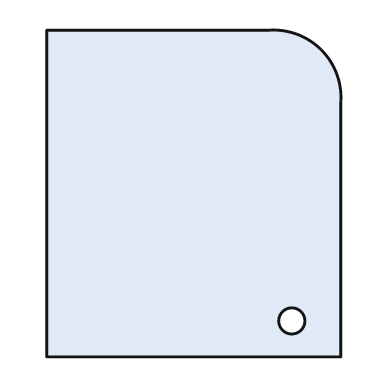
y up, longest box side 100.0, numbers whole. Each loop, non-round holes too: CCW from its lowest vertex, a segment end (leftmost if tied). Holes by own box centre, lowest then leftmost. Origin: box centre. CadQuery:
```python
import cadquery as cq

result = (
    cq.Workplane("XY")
    .moveTo(-45.0, -50.0)
    .lineTo(45.0, -50.0)
    .lineTo(45.0, 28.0)
    .threePointArc((39.0, 44.0), (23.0, 50.0))
    .lineTo(-45.0, 50.0)
    .close()
    .moveTo(30.0, -39.0)
    .circle(4.0)
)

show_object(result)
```